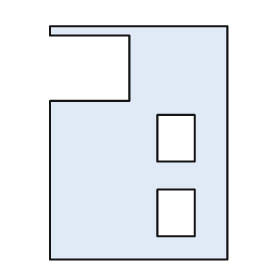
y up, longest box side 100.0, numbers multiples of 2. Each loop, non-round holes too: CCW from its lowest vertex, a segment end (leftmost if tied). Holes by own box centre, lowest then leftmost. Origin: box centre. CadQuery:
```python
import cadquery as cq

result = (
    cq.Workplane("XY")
    .moveTo(-38.0, -50.0)
    .lineTo(38.0, -50.0)
    .lineTo(38.0, 50.0)
    .lineTo(-38.0, 50.0)
    .lineTo(-38.0, 46.0)
    .lineTo(-4.0, 46.0)
    .lineTo(-4.0, 18.0)
    .lineTo(-38.0, 18.0)
    .close()
    .moveTo(8.0, -40.0)
    .lineTo(24.0, -40.0)
    .lineTo(24.0, -20.0)
    .lineTo(8.0, -20.0)
    .close()
    .moveTo(8.0, -8.0)
    .lineTo(24.0, -8.0)
    .lineTo(24.0, 12.0)
    .lineTo(8.0, 12.0)
    .close()
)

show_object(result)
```